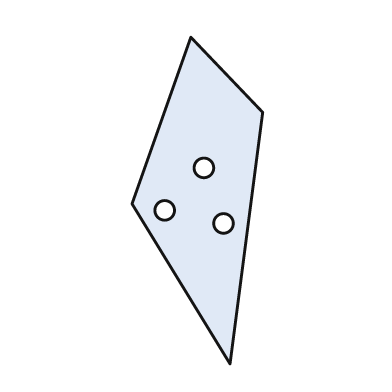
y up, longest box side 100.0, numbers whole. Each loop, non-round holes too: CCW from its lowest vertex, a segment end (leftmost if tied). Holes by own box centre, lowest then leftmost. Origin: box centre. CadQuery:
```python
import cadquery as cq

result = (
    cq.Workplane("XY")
    .moveTo(10.0, -50.0)
    .lineTo(20.0, 27.0)
    .lineTo(-2.0, 50.0)
    .lineTo(-20.0, -1.0)
    .close()
    .moveTo(8.0, -7.0)
    .circle(3.0)
    .moveTo(-10.0, -3.0)
    .circle(3.0)
    .moveTo(2.0, 10.0)
    .circle(3.0)
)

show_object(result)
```